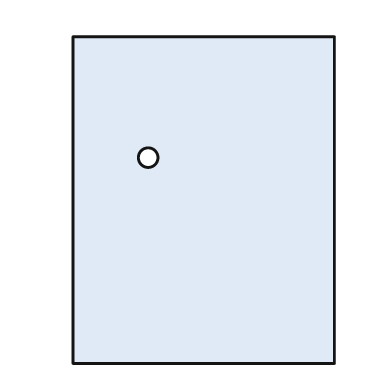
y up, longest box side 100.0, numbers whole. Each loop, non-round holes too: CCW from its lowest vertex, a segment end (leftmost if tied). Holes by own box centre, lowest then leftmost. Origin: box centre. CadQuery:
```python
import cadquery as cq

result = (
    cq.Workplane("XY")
    .moveTo(-40.0, -50.0)
    .lineTo(40.0, -50.0)
    .lineTo(40.0, 50.0)
    .lineTo(-40.0, 50.0)
    .close()
    .moveTo(-17.0, 13.0)
    .circle(3.0)
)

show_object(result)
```